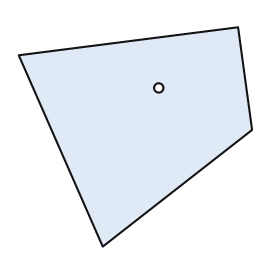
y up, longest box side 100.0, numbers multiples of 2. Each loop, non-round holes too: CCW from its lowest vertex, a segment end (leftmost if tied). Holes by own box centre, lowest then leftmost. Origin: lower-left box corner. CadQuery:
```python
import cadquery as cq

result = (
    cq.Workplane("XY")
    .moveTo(36.0, 0.0)
    .lineTo(100.0, 50.0)
    .lineTo(94.0, 94.0)
    .lineTo(0.0, 82.0)
    .close()
    .moveTo(60.0, 68.0)
    .circle(2.0)
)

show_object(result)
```